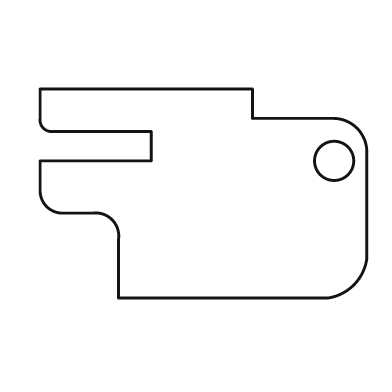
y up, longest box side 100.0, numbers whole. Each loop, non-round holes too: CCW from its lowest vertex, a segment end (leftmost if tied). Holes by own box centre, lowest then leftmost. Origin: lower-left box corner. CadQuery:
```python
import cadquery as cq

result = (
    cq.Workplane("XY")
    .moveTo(24.0, 0.0)
    .lineTo(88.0, 0.0)
    .threePointArc((96.0, 4.0), (100.0, 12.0))
    .lineTo(100.0, 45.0)
    .threePointArc((97.0, 52.0), (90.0, 55.0))
    .lineTo(65.0, 55.0)
    .lineTo(65.0, 64.0)
    .lineTo(0.0, 64.0)
    .lineTo(0.0, 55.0)
    .threePointArc((1.0, 52.0), (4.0, 51.0))
    .lineTo(34.0, 51.0)
    .lineTo(34.0, 42.0)
    .lineTo(0.0, 42.0)
    .lineTo(0.0, 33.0)
    .threePointArc((2.0, 28.0), (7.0, 26.0))
    .lineTo(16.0, 26.0)
    .threePointArc((22.0, 24.0), (24.0, 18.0))
    .close()
    .moveTo(90.0, 42.0)
    .circle(6.0)
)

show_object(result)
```